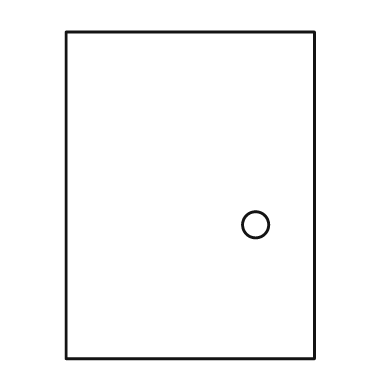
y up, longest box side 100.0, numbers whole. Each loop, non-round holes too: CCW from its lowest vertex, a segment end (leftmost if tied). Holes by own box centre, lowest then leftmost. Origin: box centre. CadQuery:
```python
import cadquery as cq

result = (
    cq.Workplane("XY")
    .moveTo(-38.0, -50.0)
    .lineTo(38.0, -50.0)
    .lineTo(38.0, 50.0)
    .lineTo(-38.0, 50.0)
    .close()
    .moveTo(20.0, -9.0)
    .circle(4.0)
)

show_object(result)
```